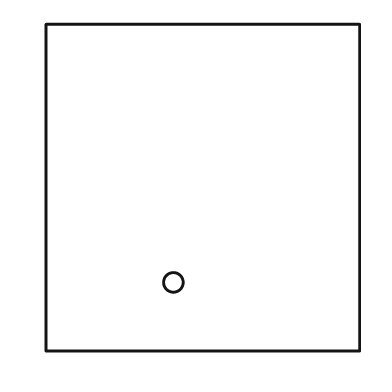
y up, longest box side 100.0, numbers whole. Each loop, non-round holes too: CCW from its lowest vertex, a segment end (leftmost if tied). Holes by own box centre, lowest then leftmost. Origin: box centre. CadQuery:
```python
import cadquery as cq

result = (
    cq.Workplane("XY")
    .moveTo(-48.0, -50.0)
    .lineTo(48.0, -50.0)
    .lineTo(48.0, 50.0)
    .lineTo(-48.0, 50.0)
    .close()
    .moveTo(-9.0, -29.0)
    .circle(3.0)
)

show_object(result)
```